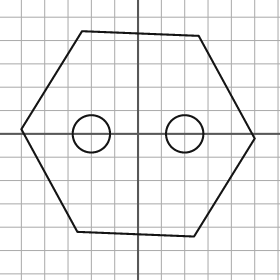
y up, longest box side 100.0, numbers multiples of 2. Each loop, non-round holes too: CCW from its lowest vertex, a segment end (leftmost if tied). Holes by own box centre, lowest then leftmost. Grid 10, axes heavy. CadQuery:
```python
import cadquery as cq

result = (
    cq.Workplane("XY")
    .moveTo(24.0, -44.0)
    .lineTo(50.0, -2.0)
    .lineTo(26.0, 42.0)
    .lineTo(-24.0, 44.0)
    .lineTo(-50.0, 2.0)
    .lineTo(-26.0, -42.0)
    .close()
    .moveTo(-20.0, 0.0)
    .circle(8.0)
    .moveTo(20.0, 0.0)
    .circle(8.0)
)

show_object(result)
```